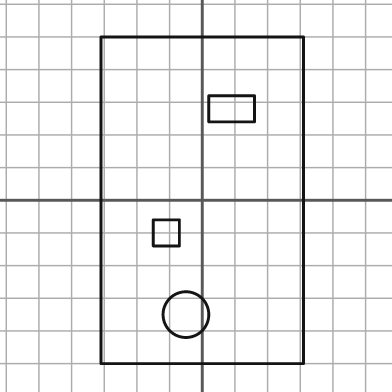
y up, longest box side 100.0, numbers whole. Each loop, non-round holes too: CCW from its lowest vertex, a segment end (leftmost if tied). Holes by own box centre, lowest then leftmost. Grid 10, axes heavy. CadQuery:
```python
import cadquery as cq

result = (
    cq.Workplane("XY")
    .moveTo(-31.0, -50.0)
    .lineTo(31.0, -50.0)
    .lineTo(31.0, 50.0)
    .lineTo(-31.0, 50.0)
    .close()
    .moveTo(-5.0, -35.0)
    .circle(7.0)
    .moveTo(-15.0, -14.0)
    .lineTo(-7.0, -14.0)
    .lineTo(-7.0, -6.0)
    .lineTo(-15.0, -6.0)
    .close()
    .moveTo(2.0, 24.0)
    .lineTo(16.0, 24.0)
    .lineTo(16.0, 32.0)
    .lineTo(2.0, 32.0)
    .close()
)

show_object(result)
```